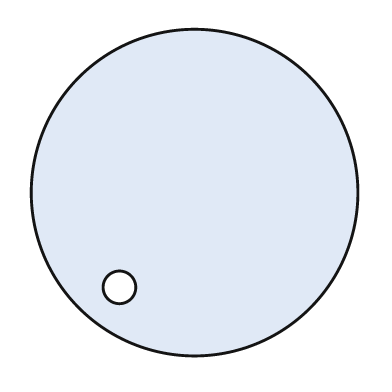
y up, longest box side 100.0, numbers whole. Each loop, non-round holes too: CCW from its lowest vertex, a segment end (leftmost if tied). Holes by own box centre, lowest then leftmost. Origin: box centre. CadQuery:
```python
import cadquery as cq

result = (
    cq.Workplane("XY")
    .moveTo(0.0, 0.0)
    .circle(50.0)
    .moveTo(-23.0, -29.0)
    .circle(5.0)
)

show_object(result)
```